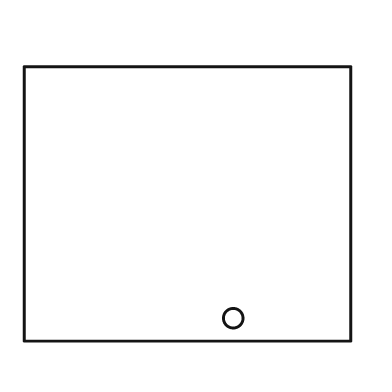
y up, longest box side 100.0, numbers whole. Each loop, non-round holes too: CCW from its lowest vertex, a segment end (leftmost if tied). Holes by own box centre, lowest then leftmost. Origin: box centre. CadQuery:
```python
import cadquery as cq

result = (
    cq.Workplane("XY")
    .moveTo(-50.0, -42.0)
    .lineTo(50.0, -42.0)
    .lineTo(50.0, 42.0)
    .lineTo(-50.0, 42.0)
    .close()
    .moveTo(14.0, -35.0)
    .circle(3.0)
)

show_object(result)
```